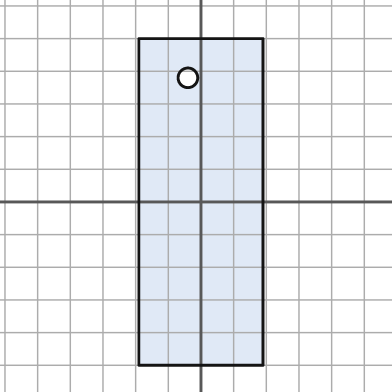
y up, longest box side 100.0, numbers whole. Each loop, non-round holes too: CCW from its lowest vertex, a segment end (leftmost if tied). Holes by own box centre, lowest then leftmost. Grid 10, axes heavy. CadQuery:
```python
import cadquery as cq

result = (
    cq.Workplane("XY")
    .moveTo(-19.0, -50.0)
    .lineTo(19.0, -50.0)
    .lineTo(19.0, 50.0)
    .lineTo(-19.0, 50.0)
    .close()
    .moveTo(-4.0, 38.0)
    .circle(3.0)
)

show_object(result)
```